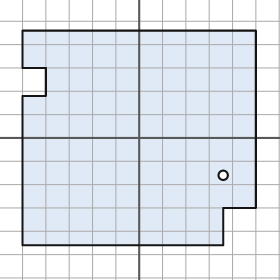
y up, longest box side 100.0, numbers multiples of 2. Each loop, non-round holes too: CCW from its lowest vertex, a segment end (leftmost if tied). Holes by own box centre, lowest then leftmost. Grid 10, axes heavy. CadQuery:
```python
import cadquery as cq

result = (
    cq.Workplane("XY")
    .moveTo(-50.0, -46.0)
    .lineTo(36.0, -46.0)
    .lineTo(36.0, -30.0)
    .lineTo(50.0, -30.0)
    .lineTo(50.0, 46.0)
    .lineTo(-50.0, 46.0)
    .lineTo(-50.0, 30.0)
    .lineTo(-40.0, 30.0)
    .lineTo(-40.0, 18.0)
    .lineTo(-50.0, 18.0)
    .close()
    .moveTo(36.0, -16.0)
    .circle(2.0)
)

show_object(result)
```